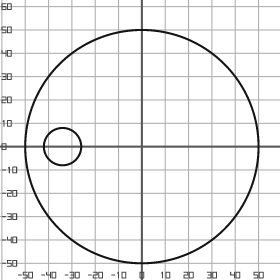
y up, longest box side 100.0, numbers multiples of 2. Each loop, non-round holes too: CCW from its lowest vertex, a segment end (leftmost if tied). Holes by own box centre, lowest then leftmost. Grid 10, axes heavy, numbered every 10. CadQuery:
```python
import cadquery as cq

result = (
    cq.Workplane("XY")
    .moveTo(0.0, 0.0)
    .circle(50.0)
    .moveTo(-34.0, 0.0)
    .circle(8.0)
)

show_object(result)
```